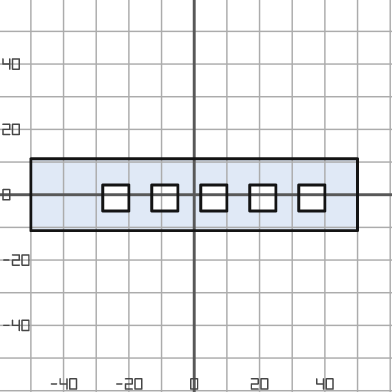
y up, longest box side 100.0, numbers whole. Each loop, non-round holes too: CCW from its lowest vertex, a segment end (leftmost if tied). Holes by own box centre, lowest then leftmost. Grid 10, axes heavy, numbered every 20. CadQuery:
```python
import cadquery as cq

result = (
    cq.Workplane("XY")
    .moveTo(-50.0, -11.0)
    .lineTo(50.0, -11.0)
    .lineTo(50.0, 11.0)
    .lineTo(-50.0, 11.0)
    .close()
    .moveTo(-28.0, -5.0)
    .lineTo(-20.0, -5.0)
    .lineTo(-20.0, 3.0)
    .lineTo(-28.0, 3.0)
    .close()
    .moveTo(-13.0, -5.0)
    .lineTo(-5.0, -5.0)
    .lineTo(-5.0, 3.0)
    .lineTo(-13.0, 3.0)
    .close()
    .moveTo(2.0, -5.0)
    .lineTo(10.0, -5.0)
    .lineTo(10.0, 3.0)
    .lineTo(2.0, 3.0)
    .close()
    .moveTo(17.0, -5.0)
    .lineTo(25.0, -5.0)
    .lineTo(25.0, 3.0)
    .lineTo(17.0, 3.0)
    .close()
    .moveTo(32.0, -5.0)
    .lineTo(40.0, -5.0)
    .lineTo(40.0, 3.0)
    .lineTo(32.0, 3.0)
    .close()
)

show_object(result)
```